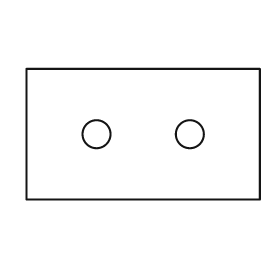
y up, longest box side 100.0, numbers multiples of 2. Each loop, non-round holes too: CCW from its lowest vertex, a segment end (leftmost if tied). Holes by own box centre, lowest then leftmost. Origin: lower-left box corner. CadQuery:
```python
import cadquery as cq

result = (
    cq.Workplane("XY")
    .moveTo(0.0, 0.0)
    .lineTo(100.0, 0.0)
    .lineTo(100.0, 56.0)
    .lineTo(0.0, 56.0)
    .close()
    .moveTo(30.0, 28.0)
    .circle(6.0)
    .moveTo(70.0, 28.0)
    .circle(6.0)
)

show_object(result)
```